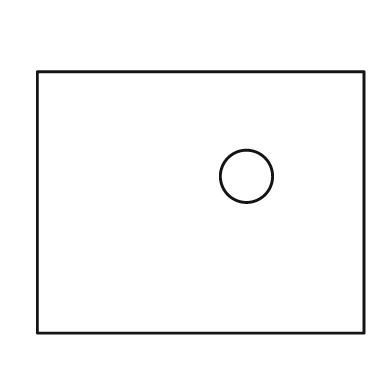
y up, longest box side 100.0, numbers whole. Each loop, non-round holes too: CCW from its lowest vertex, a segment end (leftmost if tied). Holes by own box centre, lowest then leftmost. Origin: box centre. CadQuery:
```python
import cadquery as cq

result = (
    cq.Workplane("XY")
    .moveTo(-50.0, -40.0)
    .lineTo(50.0, -40.0)
    .lineTo(50.0, 40.0)
    .lineTo(-50.0, 40.0)
    .close()
    .moveTo(14.0, 8.0)
    .circle(8.0)
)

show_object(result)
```